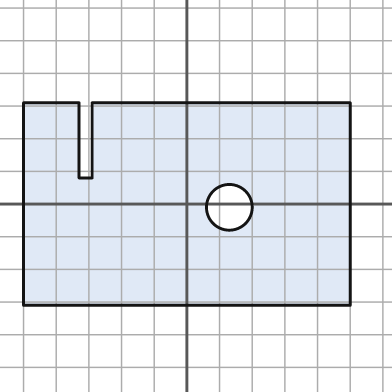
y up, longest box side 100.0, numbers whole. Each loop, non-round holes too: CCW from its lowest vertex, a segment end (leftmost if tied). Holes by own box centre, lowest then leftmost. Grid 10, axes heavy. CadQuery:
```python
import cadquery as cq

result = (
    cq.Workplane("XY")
    .moveTo(-50.0, -31.0)
    .lineTo(50.0, -31.0)
    .lineTo(50.0, 31.0)
    .lineTo(-29.0, 31.0)
    .lineTo(-29.0, 8.0)
    .lineTo(-33.0, 8.0)
    .lineTo(-33.0, 31.0)
    .lineTo(-50.0, 31.0)
    .close()
    .moveTo(13.0, -1.0)
    .circle(7.0)
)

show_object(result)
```